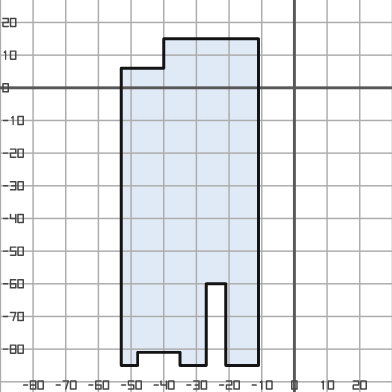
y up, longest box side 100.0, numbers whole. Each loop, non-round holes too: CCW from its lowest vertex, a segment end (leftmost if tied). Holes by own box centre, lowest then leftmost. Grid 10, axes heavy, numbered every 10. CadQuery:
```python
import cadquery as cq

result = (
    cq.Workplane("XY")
    .moveTo(-53.0, -85.0)
    .lineTo(-48.0, -85.0)
    .lineTo(-48.0, -81.0)
    .lineTo(-35.0, -81.0)
    .lineTo(-35.0, -85.0)
    .lineTo(-27.0, -85.0)
    .lineTo(-27.0, -60.0)
    .lineTo(-21.0, -60.0)
    .lineTo(-21.0, -85.0)
    .lineTo(-11.0, -85.0)
    .lineTo(-11.0, 15.0)
    .lineTo(-40.0, 15.0)
    .lineTo(-40.0, 6.0)
    .lineTo(-53.0, 6.0)
    .close()
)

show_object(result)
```